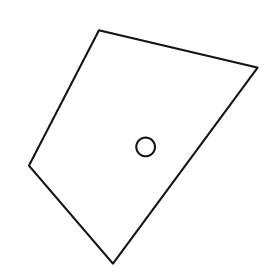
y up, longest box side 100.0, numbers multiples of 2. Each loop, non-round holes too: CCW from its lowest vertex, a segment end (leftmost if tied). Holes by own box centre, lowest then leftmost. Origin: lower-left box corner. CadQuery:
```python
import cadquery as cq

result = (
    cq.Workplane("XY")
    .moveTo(36.0, 0.0)
    .lineTo(98.0, 84.0)
    .lineTo(30.0, 100.0)
    .lineTo(0.0, 42.0)
    .close()
    .moveTo(50.0, 50.0)
    .circle(4.0)
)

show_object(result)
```